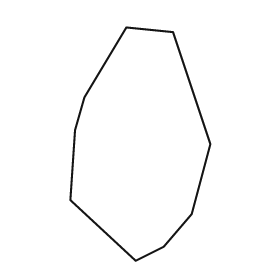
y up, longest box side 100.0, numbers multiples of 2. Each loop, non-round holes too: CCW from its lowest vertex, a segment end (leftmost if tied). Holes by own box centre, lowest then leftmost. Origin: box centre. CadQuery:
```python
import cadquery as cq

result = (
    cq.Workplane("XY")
    .moveTo(-2.0, -50.0)
    .lineTo(10.0, -44.0)
    .lineTo(22.0, -30.0)
    .lineTo(30.0, 0.0)
    .lineTo(14.0, 48.0)
    .lineTo(-6.0, 50.0)
    .lineTo(-24.0, 20.0)
    .lineTo(-28.0, 6.0)
    .lineTo(-30.0, -24.0)
    .close()
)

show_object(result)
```